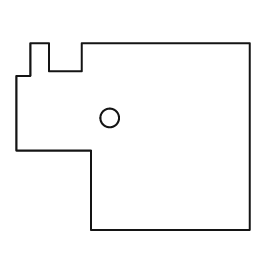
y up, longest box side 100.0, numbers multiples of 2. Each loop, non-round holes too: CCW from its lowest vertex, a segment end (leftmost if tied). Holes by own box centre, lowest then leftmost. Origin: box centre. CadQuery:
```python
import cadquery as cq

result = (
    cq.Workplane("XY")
    .moveTo(-18.0, -40.0)
    .lineTo(50.0, -40.0)
    .lineTo(50.0, 40.0)
    .lineTo(-22.0, 40.0)
    .lineTo(-22.0, 28.0)
    .lineTo(-36.0, 28.0)
    .lineTo(-36.0, 40.0)
    .lineTo(-44.0, 40.0)
    .lineTo(-44.0, 26.0)
    .lineTo(-50.0, 26.0)
    .lineTo(-50.0, -6.0)
    .lineTo(-18.0, -6.0)
    .close()
    .moveTo(-10.0, 8.0)
    .circle(4.0)
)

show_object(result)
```